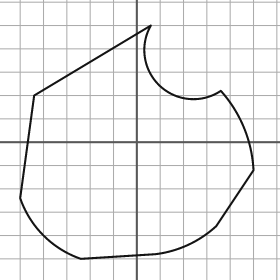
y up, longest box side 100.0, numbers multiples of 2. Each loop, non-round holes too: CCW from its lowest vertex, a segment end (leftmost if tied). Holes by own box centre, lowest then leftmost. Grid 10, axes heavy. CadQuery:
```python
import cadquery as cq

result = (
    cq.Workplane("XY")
    .moveTo(-24.0, -50.0)
    .lineTo(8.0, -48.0)
    .threePointArc((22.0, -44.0), (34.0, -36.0))
    .lineTo(50.0, -12.0)
    .threePointArc((46.0, 6.0), (36.0, 22.0))
    .threePointArc((10.0, 24.0), (6.0, 50.0))
    .lineTo(-44.0, 20.0)
    .lineTo(-50.0, -24.0)
    .threePointArc((-40.0, -40.0), (-24.0, -50.0))
    .close()
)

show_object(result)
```